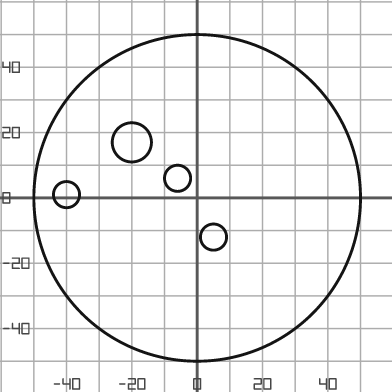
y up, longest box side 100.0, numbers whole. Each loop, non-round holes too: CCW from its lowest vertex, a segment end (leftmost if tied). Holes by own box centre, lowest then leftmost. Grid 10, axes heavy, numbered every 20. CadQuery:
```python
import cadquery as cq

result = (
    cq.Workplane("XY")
    .moveTo(0.0, 0.0)
    .circle(50.0)
    .moveTo(5.0, -12.0)
    .circle(4.0)
    .moveTo(-40.0, 1.0)
    .circle(4.0)
    .moveTo(-6.0, 6.0)
    .circle(4.0)
    .moveTo(-20.0, 17.0)
    .circle(6.0)
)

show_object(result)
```